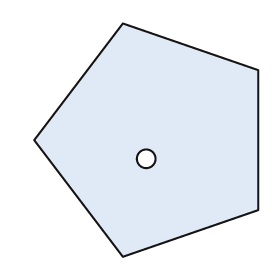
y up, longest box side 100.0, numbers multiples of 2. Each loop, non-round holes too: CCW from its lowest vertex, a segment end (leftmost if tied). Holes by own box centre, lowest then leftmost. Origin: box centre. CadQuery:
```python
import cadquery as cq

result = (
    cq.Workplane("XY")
    .moveTo(-10.0, -50.0)
    .lineTo(48.0, -30.0)
    .lineTo(48.0, 30.0)
    .lineTo(-10.0, 50.0)
    .lineTo(-48.0, 0.0)
    .close()
    .moveTo(0.0, -8.0)
    .circle(4.0)
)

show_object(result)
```